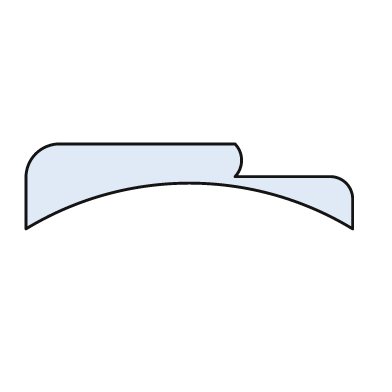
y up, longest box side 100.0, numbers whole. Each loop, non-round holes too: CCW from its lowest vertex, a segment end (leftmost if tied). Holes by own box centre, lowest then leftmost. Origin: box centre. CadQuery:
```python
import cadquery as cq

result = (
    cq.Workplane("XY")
    .moveTo(-50.0, -13.0)
    .threePointArc((0.0, 1.0), (50.0, -13.0))
    .lineTo(50.0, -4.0)
    .threePointArc((48.0, 1.0), (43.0, 3.0))
    .lineTo(14.0, 3.0)
    .threePointArc((16.0, 8.0), (14.0, 13.0))
    .lineTo(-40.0, 13.0)
    .threePointArc((-47.0, 10.0), (-50.0, 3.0))
    .close()
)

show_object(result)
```